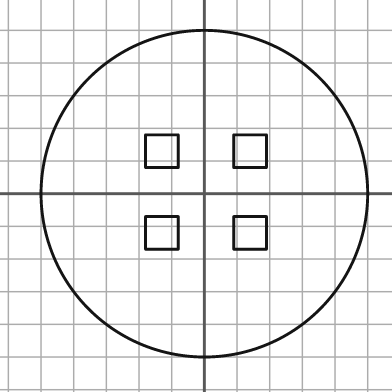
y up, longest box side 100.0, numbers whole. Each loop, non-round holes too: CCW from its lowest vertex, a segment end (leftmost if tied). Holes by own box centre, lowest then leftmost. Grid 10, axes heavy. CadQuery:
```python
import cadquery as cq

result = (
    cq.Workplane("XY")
    .moveTo(0.0, 0.0)
    .circle(50.0)
    .moveTo(-18.0, -17.0)
    .lineTo(-8.0, -17.0)
    .lineTo(-8.0, -7.0)
    .lineTo(-18.0, -7.0)
    .close()
    .moveTo(9.0, -17.0)
    .lineTo(19.0, -17.0)
    .lineTo(19.0, -7.0)
    .lineTo(9.0, -7.0)
    .close()
    .moveTo(-18.0, 8.0)
    .lineTo(-8.0, 8.0)
    .lineTo(-8.0, 18.0)
    .lineTo(-18.0, 18.0)
    .close()
    .moveTo(9.0, 8.0)
    .lineTo(19.0, 8.0)
    .lineTo(19.0, 18.0)
    .lineTo(9.0, 18.0)
    .close()
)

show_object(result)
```